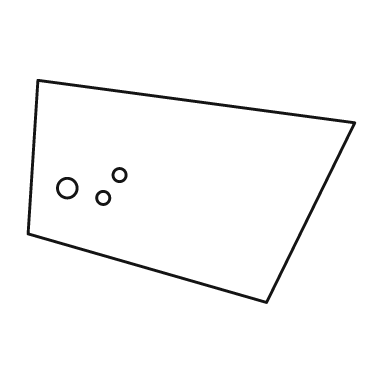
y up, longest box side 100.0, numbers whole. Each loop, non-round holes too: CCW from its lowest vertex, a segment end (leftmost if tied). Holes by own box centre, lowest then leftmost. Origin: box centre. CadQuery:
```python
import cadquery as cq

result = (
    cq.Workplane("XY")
    .moveTo(23.0, -34.0)
    .lineTo(50.0, 21.0)
    .lineTo(-47.0, 34.0)
    .lineTo(-50.0, -13.0)
    .close()
    .moveTo(-27.0, -2.0)
    .circle(2.0)
    .moveTo(-38.0, 1.0)
    .circle(3.0)
    .moveTo(-22.0, 5.0)
    .circle(2.0)
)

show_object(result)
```